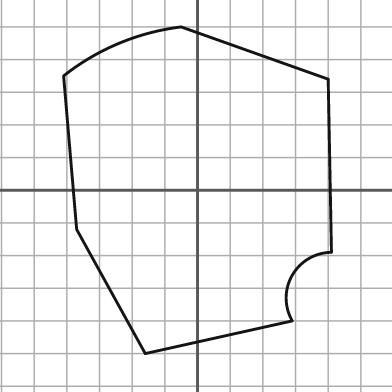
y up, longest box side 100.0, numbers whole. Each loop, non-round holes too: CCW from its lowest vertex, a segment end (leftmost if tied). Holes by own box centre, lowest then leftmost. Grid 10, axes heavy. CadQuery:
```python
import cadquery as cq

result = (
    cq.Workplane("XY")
    .moveTo(-16.0, -50.0)
    .lineTo(29.0, -40.0)
    .threePointArc((29.0, -26.0), (41.0, -19.0))
    .lineTo(40.0, 34.0)
    .lineTo(-5.0, 50.0)
    .threePointArc((-24.0, 45.0), (-41.0, 35.0))
    .lineTo(-37.0, -12.0)
    .close()
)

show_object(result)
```